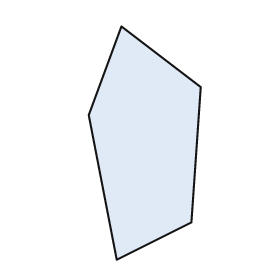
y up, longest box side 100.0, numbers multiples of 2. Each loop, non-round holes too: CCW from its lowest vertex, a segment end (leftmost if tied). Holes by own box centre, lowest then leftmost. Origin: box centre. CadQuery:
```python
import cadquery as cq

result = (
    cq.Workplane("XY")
    .moveTo(-12.0, -50.0)
    .lineTo(20.0, -34.0)
    .lineTo(24.0, 24.0)
    .lineTo(-10.0, 50.0)
    .lineTo(-24.0, 12.0)
    .close()
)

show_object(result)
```